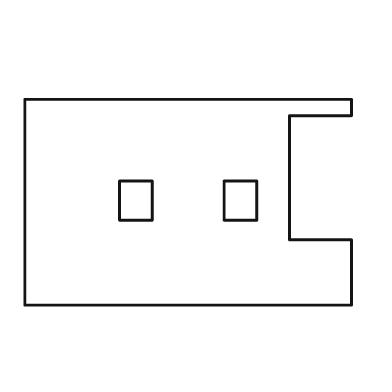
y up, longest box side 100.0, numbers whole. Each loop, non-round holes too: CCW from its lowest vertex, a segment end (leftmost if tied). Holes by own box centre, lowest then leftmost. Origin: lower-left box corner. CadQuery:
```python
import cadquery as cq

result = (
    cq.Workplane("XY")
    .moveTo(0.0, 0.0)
    .lineTo(100.0, 0.0)
    .lineTo(100.0, 20.0)
    .lineTo(81.0, 20.0)
    .lineTo(81.0, 58.0)
    .lineTo(100.0, 58.0)
    .lineTo(100.0, 63.0)
    .lineTo(0.0, 63.0)
    .close()
    .moveTo(29.0, 26.0)
    .lineTo(39.0, 26.0)
    .lineTo(39.0, 38.0)
    .lineTo(29.0, 38.0)
    .close()
    .moveTo(61.0, 26.0)
    .lineTo(71.0, 26.0)
    .lineTo(71.0, 38.0)
    .lineTo(61.0, 38.0)
    .close()
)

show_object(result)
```